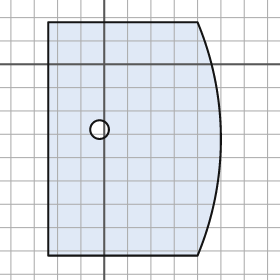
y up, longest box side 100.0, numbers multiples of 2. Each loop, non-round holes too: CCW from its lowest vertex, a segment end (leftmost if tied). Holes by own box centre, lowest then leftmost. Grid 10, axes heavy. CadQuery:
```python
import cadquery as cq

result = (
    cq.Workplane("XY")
    .moveTo(-24.0, -82.0)
    .lineTo(40.0, -82.0)
    .threePointArc((50.0, -32.0), (40.0, 18.0))
    .lineTo(-24.0, 18.0)
    .close()
    .moveTo(-2.0, -28.0)
    .circle(4.0)
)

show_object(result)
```